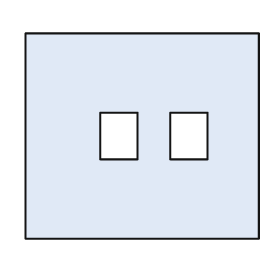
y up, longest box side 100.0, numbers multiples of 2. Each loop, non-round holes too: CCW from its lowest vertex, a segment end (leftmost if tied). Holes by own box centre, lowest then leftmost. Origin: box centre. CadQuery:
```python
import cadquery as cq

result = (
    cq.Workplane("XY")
    .moveTo(-50.0, -44.0)
    .lineTo(50.0, -44.0)
    .lineTo(50.0, 44.0)
    .lineTo(-50.0, 44.0)
    .close()
    .moveTo(-18.0, -10.0)
    .lineTo(-2.0, -10.0)
    .lineTo(-2.0, 10.0)
    .lineTo(-18.0, 10.0)
    .close()
    .moveTo(12.0, -10.0)
    .lineTo(28.0, -10.0)
    .lineTo(28.0, 10.0)
    .lineTo(12.0, 10.0)
    .close()
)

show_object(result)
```